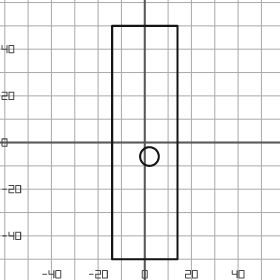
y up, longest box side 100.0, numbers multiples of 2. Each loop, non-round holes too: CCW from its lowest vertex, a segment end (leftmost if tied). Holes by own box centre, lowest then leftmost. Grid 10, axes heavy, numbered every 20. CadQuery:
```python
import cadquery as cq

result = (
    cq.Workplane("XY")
    .moveTo(-14.0, -50.0)
    .lineTo(14.0, -50.0)
    .lineTo(14.0, 50.0)
    .lineTo(-14.0, 50.0)
    .close()
    .moveTo(2.0, -6.0)
    .circle(4.0)
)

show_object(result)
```